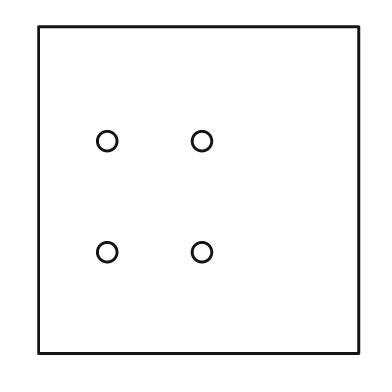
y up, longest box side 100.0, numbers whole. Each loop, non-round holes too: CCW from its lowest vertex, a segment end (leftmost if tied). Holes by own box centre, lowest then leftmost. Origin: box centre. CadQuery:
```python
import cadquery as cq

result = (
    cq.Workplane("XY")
    .moveTo(-49.0, -50.0)
    .lineTo(49.0, -50.0)
    .lineTo(49.0, 50.0)
    .lineTo(-49.0, 50.0)
    .close()
    .moveTo(-28.0, -19.0)
    .circle(3.0)
    .moveTo(1.0, -19.0)
    .circle(3.0)
    .moveTo(-28.0, 15.0)
    .circle(3.0)
    .moveTo(1.0, 15.0)
    .circle(3.0)
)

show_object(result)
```